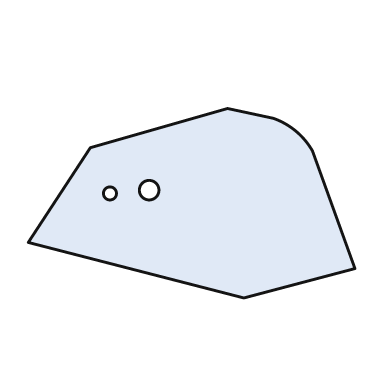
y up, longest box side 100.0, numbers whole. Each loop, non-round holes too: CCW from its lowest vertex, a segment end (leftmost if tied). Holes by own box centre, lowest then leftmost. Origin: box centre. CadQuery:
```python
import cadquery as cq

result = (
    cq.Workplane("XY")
    .moveTo(16.0, -29.0)
    .lineTo(50.0, -20.0)
    .lineTo(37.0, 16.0)
    .threePointArc((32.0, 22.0), (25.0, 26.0))
    .lineTo(11.0, 29.0)
    .lineTo(-31.0, 17.0)
    .lineTo(-50.0, -12.0)
    .close()
    .moveTo(-25.0, 3.0)
    .circle(2.0)
    .moveTo(-13.0, 4.0)
    .circle(3.0)
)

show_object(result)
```